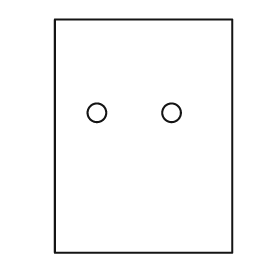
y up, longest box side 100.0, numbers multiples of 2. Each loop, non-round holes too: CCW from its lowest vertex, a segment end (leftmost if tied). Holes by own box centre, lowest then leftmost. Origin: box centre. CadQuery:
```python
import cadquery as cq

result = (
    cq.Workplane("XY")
    .moveTo(-38.0, -50.0)
    .lineTo(38.0, -50.0)
    .lineTo(38.0, 50.0)
    .lineTo(-38.0, 50.0)
    .close()
    .moveTo(-20.0, 10.0)
    .circle(4.0)
    .moveTo(12.0, 10.0)
    .circle(4.0)
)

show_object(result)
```